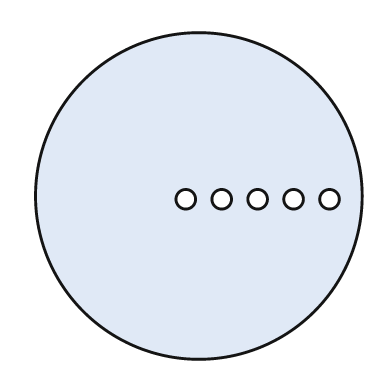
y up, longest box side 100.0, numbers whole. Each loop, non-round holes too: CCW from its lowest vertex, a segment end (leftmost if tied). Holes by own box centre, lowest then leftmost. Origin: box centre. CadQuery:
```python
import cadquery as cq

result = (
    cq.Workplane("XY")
    .moveTo(0.0, 0.0)
    .circle(50.0)
    .moveTo(-4.0, -1.0)
    .circle(3.0)
    .moveTo(7.0, -1.0)
    .circle(3.0)
    .moveTo(18.0, -1.0)
    .circle(3.0)
    .moveTo(29.0, -1.0)
    .circle(3.0)
    .moveTo(40.0, -1.0)
    .circle(3.0)
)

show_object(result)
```